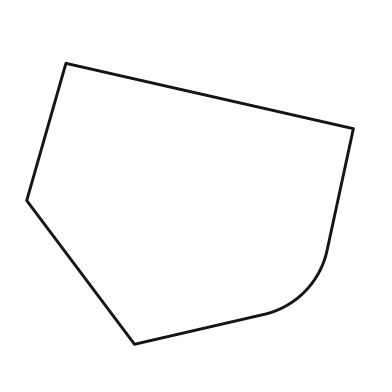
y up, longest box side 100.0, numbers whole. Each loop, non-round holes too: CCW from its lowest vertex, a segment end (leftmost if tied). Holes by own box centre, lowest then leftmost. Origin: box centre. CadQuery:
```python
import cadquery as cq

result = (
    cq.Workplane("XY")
    .moveTo(-17.0, -43.0)
    .lineTo(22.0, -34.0)
    .threePointArc((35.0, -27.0), (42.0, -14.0))
    .lineTo(50.0, 23.0)
    .lineTo(-38.0, 43.0)
    .lineTo(-50.0, 1.0)
    .close()
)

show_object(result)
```